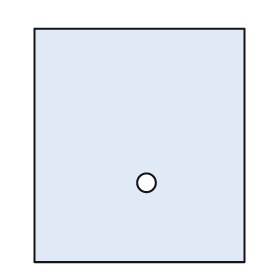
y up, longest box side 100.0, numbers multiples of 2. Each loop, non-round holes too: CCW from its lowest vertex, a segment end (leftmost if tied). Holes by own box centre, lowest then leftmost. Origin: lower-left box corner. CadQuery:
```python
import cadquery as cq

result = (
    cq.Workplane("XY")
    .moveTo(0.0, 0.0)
    .lineTo(90.0, 0.0)
    .lineTo(90.0, 100.0)
    .lineTo(0.0, 100.0)
    .close()
    .moveTo(48.0, 34.0)
    .circle(4.0)
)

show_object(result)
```